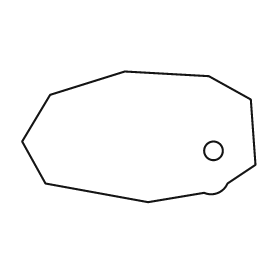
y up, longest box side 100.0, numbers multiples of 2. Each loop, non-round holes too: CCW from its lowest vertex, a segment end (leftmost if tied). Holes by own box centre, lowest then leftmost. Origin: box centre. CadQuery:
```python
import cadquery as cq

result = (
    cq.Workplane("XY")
    .moveTo(4.0, -28.0)
    .lineTo(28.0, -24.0)
    .threePointArc((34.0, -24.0), (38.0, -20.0))
    .lineTo(50.0, -12.0)
    .lineTo(48.0, 16.0)
    .lineTo(30.0, 26.0)
    .lineTo(-6.0, 28.0)
    .lineTo(-38.0, 18.0)
    .lineTo(-50.0, -2.0)
    .lineTo(-40.0, -20.0)
    .close()
    .moveTo(32.0, -6.0)
    .circle(4.0)
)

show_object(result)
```